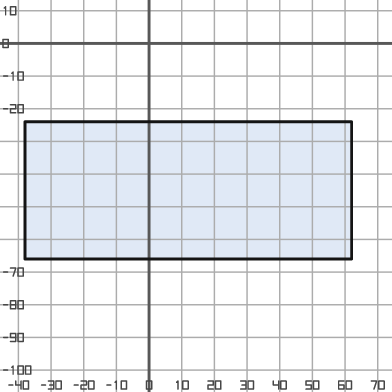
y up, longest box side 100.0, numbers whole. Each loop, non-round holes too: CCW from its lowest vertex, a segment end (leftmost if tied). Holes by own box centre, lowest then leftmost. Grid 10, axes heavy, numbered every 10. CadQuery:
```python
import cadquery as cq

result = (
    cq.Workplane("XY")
    .moveTo(-38.0, -66.0)
    .lineTo(62.0, -66.0)
    .lineTo(62.0, -24.0)
    .lineTo(-38.0, -24.0)
    .close()
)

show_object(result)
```